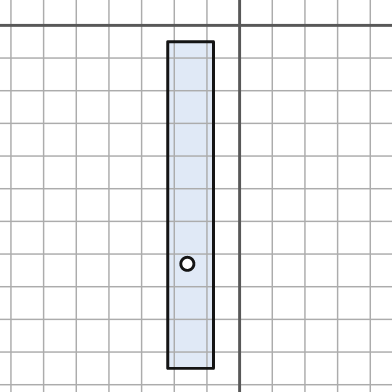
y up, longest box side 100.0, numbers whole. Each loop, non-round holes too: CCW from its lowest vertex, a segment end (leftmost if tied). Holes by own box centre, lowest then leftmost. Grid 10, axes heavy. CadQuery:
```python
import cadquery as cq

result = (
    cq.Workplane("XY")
    .moveTo(-22.0, -105.0)
    .lineTo(-8.0, -105.0)
    .lineTo(-8.0, -5.0)
    .lineTo(-22.0, -5.0)
    .close()
    .moveTo(-16.0, -73.0)
    .circle(2.0)
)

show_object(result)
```